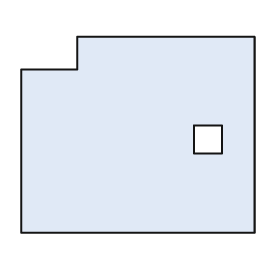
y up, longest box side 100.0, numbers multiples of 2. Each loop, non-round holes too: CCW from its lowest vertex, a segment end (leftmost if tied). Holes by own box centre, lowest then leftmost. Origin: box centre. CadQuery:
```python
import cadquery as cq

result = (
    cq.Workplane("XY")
    .moveTo(-50.0, -42.0)
    .lineTo(50.0, -42.0)
    .lineTo(50.0, 42.0)
    .lineTo(-26.0, 42.0)
    .lineTo(-26.0, 28.0)
    .lineTo(-50.0, 28.0)
    .close()
    .moveTo(24.0, -8.0)
    .lineTo(36.0, -8.0)
    .lineTo(36.0, 4.0)
    .lineTo(24.0, 4.0)
    .close()
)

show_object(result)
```